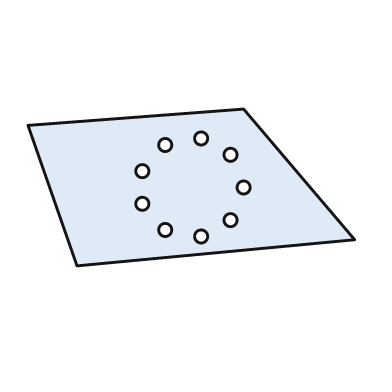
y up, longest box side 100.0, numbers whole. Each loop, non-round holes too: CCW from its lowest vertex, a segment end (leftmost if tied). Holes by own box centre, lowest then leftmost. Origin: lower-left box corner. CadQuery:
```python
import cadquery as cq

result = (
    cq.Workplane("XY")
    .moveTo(15.0, 0.0)
    .lineTo(100.0, 8.0)
    .lineTo(66.0, 48.0)
    .lineTo(0.0, 43.0)
    .close()
    .moveTo(53.0, 9.0)
    .circle(2.0)
    .moveTo(42.0, 11.0)
    .circle(2.0)
    .moveTo(62.0, 14.0)
    .circle(2.0)
    .moveTo(35.0, 19.0)
    .circle(2.0)
    .moveTo(66.0, 24.0)
    .circle(2.0)
    .moveTo(35.0, 29.0)
    .circle(2.0)
    .moveTo(62.0, 34.0)
    .circle(2.0)
    .moveTo(42.0, 37.0)
    .circle(2.0)
    .moveTo(53.0, 39.0)
    .circle(2.0)
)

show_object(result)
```